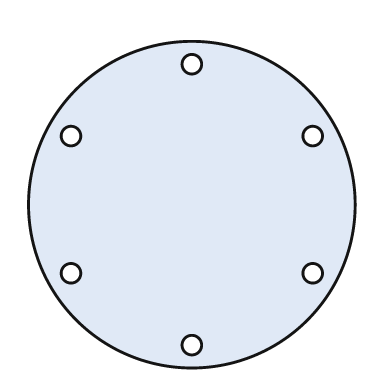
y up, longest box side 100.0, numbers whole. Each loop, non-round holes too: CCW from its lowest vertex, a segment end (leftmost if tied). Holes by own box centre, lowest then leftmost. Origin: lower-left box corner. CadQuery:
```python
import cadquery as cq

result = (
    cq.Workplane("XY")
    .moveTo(50.0, 50.0)
    .circle(50.0)
    .moveTo(50.0, 7.0)
    .circle(3.0)
    .moveTo(13.0, 29.0)
    .circle(3.0)
    .moveTo(87.0, 29.0)
    .circle(3.0)
    .moveTo(13.0, 71.0)
    .circle(3.0)
    .moveTo(87.0, 71.0)
    .circle(3.0)
    .moveTo(50.0, 93.0)
    .circle(3.0)
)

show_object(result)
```